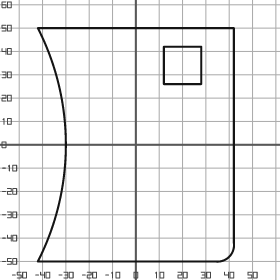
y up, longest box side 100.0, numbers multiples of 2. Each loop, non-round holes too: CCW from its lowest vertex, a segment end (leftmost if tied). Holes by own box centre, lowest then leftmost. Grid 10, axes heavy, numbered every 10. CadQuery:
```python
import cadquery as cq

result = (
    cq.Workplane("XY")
    .moveTo(-42.0, -50.0)
    .lineTo(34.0, -50.0)
    .threePointArc((40.0, -48.0), (42.0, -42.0))
    .lineTo(42.0, 50.0)
    .lineTo(-42.0, 50.0)
    .threePointArc((-30.0, 0.0), (-42.0, -50.0))
    .close()
    .moveTo(12.0, 26.0)
    .lineTo(28.0, 26.0)
    .lineTo(28.0, 42.0)
    .lineTo(12.0, 42.0)
    .close()
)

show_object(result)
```